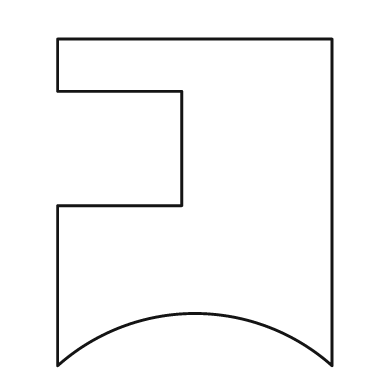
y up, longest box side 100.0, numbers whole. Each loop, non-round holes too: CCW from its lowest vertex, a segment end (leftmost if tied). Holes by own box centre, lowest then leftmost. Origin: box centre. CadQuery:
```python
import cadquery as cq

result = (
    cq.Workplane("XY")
    .moveTo(-42.0, -50.0)
    .threePointArc((0.0, -34.0), (42.0, -50.0))
    .lineTo(42.0, 50.0)
    .lineTo(-42.0, 50.0)
    .lineTo(-42.0, 34.0)
    .lineTo(-4.0, 34.0)
    .lineTo(-4.0, -1.0)
    .lineTo(-42.0, -1.0)
    .close()
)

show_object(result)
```